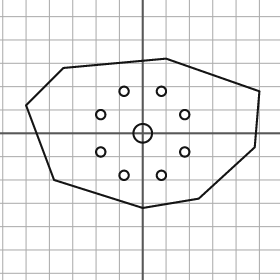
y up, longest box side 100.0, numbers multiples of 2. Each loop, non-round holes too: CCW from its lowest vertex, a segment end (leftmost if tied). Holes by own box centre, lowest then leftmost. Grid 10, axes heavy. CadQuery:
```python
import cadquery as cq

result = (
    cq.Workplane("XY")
    .moveTo(0.0, -32.0)
    .lineTo(24.0, -28.0)
    .lineTo(48.0, -6.0)
    .lineTo(50.0, 18.0)
    .lineTo(10.0, 32.0)
    .lineTo(-34.0, 28.0)
    .lineTo(-50.0, 12.0)
    .lineTo(-38.0, -20.0)
    .close()
    .moveTo(-8.0, -18.0)
    .circle(2.0)
    .moveTo(8.0, -18.0)
    .circle(2.0)
    .moveTo(-18.0, -8.0)
    .circle(2.0)
    .moveTo(18.0, -8.0)
    .circle(2.0)
    .moveTo(0.0, 0.0)
    .circle(4.0)
    .moveTo(-18.0, 8.0)
    .circle(2.0)
    .moveTo(18.0, 8.0)
    .circle(2.0)
    .moveTo(-8.0, 18.0)
    .circle(2.0)
    .moveTo(8.0, 18.0)
    .circle(2.0)
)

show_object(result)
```